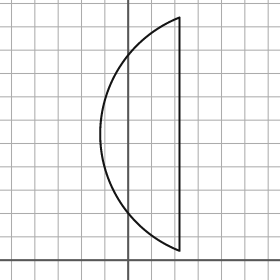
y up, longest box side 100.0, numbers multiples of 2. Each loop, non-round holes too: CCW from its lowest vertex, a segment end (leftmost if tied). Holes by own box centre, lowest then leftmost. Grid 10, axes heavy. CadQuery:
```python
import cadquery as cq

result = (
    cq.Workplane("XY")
    .moveTo(22.0, 4.0)
    .lineTo(22.0, 104.0)
    .threePointArc((-12.0, 54.0), (22.0, 4.0))
    .close()
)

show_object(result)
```